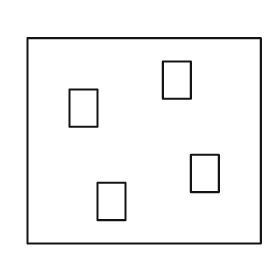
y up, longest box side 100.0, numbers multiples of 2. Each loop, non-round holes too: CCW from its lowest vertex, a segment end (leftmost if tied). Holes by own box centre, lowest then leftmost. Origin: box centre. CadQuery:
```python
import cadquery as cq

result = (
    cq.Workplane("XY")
    .moveTo(-50.0, -44.0)
    .lineTo(50.0, -44.0)
    .lineTo(50.0, 44.0)
    .lineTo(-50.0, 44.0)
    .close()
    .moveTo(-20.0, -34.0)
    .lineTo(-8.0, -34.0)
    .lineTo(-8.0, -18.0)
    .lineTo(-20.0, -18.0)
    .close()
    .moveTo(20.0, -22.0)
    .lineTo(32.0, -22.0)
    .lineTo(32.0, -6.0)
    .lineTo(20.0, -6.0)
    .close()
    .moveTo(-32.0, 6.0)
    .lineTo(-20.0, 6.0)
    .lineTo(-20.0, 22.0)
    .lineTo(-32.0, 22.0)
    .close()
    .moveTo(8.0, 18.0)
    .lineTo(20.0, 18.0)
    .lineTo(20.0, 34.0)
    .lineTo(8.0, 34.0)
    .close()
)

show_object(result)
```